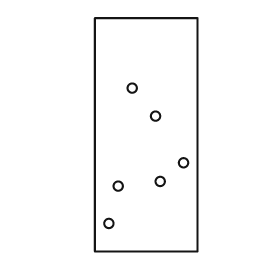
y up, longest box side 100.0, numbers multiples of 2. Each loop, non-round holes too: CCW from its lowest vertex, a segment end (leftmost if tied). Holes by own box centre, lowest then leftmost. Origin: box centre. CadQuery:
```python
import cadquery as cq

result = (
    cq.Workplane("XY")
    .moveTo(-22.0, -50.0)
    .lineTo(22.0, -50.0)
    .lineTo(22.0, 50.0)
    .lineTo(-22.0, 50.0)
    .close()
    .moveTo(-16.0, -38.0)
    .circle(2.0)
    .moveTo(-12.0, -22.0)
    .circle(2.0)
    .moveTo(6.0, -20.0)
    .circle(2.0)
    .moveTo(16.0, -12.0)
    .circle(2.0)
    .moveTo(4.0, 8.0)
    .circle(2.0)
    .moveTo(-6.0, 20.0)
    .circle(2.0)
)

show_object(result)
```